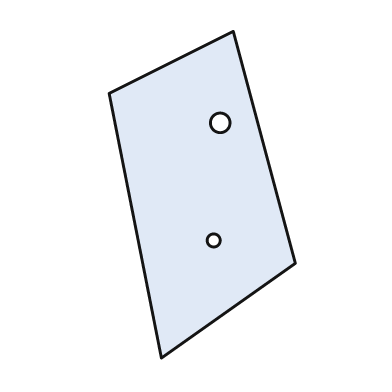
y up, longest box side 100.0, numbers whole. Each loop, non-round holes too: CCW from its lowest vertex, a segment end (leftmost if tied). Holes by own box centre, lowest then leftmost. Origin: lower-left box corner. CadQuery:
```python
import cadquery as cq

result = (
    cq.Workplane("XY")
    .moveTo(16.0, 0.0)
    .lineTo(57.0, 29.0)
    .lineTo(38.0, 100.0)
    .lineTo(0.0, 81.0)
    .close()
    .moveTo(32.0, 36.0)
    .circle(2.0)
    .moveTo(34.0, 72.0)
    .circle(3.0)
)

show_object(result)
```